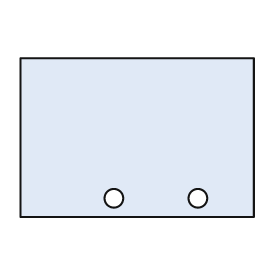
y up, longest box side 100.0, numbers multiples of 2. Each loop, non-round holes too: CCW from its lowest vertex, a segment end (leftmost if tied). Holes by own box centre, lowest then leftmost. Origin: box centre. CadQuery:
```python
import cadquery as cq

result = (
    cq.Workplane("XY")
    .moveTo(-50.0, -34.0)
    .lineTo(50.0, -34.0)
    .lineTo(50.0, 34.0)
    .lineTo(-50.0, 34.0)
    .close()
    .moveTo(-10.0, -26.0)
    .circle(4.0)
    .moveTo(26.0, -26.0)
    .circle(4.0)
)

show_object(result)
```